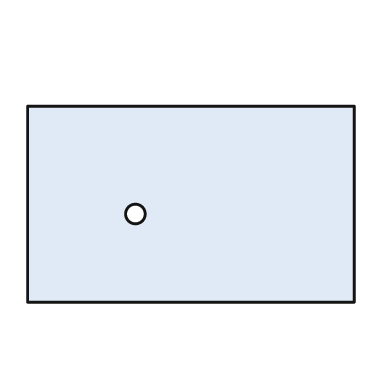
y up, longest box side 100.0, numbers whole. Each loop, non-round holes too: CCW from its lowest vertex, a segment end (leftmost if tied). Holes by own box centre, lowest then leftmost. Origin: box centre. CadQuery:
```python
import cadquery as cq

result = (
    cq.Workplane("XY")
    .moveTo(-50.0, -30.0)
    .lineTo(50.0, -30.0)
    .lineTo(50.0, 30.0)
    .lineTo(-50.0, 30.0)
    .close()
    .moveTo(-17.0, -3.0)
    .circle(3.0)
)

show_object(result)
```